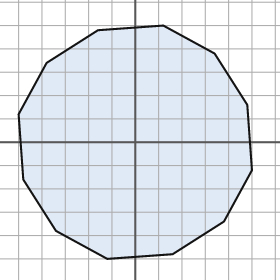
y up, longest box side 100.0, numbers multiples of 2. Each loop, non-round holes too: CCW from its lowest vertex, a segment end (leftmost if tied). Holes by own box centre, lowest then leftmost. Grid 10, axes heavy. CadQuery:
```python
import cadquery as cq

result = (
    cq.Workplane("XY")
    .moveTo(-12.0, -50.0)
    .lineTo(16.0, -48.0)
    .lineTo(38.0, -34.0)
    .lineTo(50.0, -12.0)
    .lineTo(48.0, 16.0)
    .lineTo(34.0, 38.0)
    .lineTo(12.0, 50.0)
    .lineTo(-16.0, 48.0)
    .lineTo(-38.0, 34.0)
    .lineTo(-50.0, 12.0)
    .lineTo(-48.0, -16.0)
    .lineTo(-34.0, -38.0)
    .close()
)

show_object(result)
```